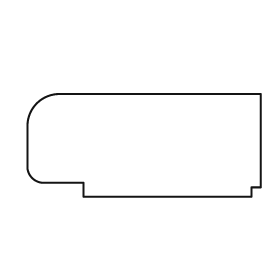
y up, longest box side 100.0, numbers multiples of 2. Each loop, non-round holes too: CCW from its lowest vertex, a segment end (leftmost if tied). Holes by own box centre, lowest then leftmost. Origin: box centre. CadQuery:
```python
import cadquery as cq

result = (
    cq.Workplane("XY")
    .moveTo(-26.0, -22.0)
    .lineTo(46.0, -22.0)
    .lineTo(46.0, -18.0)
    .lineTo(50.0, -18.0)
    .lineTo(50.0, 22.0)
    .lineTo(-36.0, 22.0)
    .threePointArc((-46.0, 18.0), (-50.0, 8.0))
    .lineTo(-50.0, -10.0)
    .threePointArc((-48.0, -14.0), (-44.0, -16.0))
    .lineTo(-26.0, -16.0)
    .close()
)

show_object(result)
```